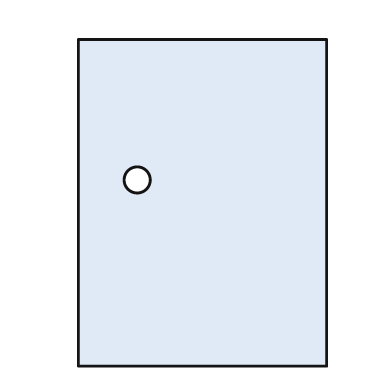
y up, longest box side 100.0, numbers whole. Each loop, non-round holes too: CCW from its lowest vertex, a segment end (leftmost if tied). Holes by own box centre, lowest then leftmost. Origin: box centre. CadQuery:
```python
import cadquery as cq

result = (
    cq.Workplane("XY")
    .moveTo(-38.0, -50.0)
    .lineTo(38.0, -50.0)
    .lineTo(38.0, 50.0)
    .lineTo(-38.0, 50.0)
    .close()
    .moveTo(-20.0, 7.0)
    .circle(4.0)
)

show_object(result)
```